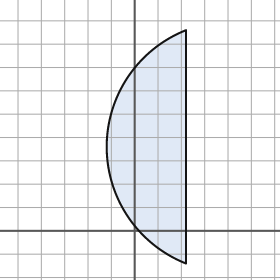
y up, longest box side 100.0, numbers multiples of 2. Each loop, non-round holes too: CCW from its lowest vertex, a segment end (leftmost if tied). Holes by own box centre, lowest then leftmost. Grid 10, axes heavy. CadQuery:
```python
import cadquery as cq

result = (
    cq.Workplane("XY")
    .moveTo(22.0, -14.0)
    .lineTo(22.0, 86.0)
    .threePointArc((-12.0, 36.0), (22.0, -14.0))
    .close()
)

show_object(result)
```